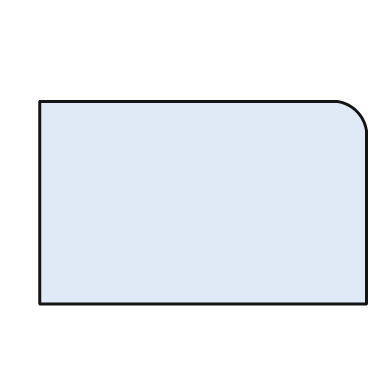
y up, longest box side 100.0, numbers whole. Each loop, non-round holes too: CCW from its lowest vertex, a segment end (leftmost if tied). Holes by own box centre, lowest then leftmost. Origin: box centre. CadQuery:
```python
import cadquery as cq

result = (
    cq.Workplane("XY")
    .moveTo(-50.0, -31.0)
    .lineTo(50.0, -31.0)
    .lineTo(50.0, 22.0)
    .threePointArc((47.0, 28.0), (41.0, 31.0))
    .lineTo(-50.0, 31.0)
    .close()
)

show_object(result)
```